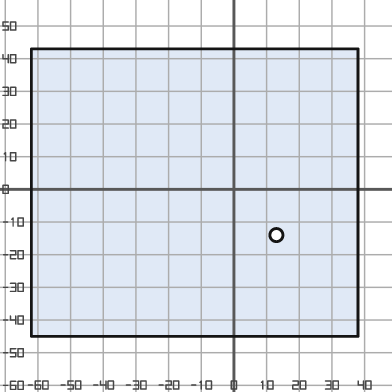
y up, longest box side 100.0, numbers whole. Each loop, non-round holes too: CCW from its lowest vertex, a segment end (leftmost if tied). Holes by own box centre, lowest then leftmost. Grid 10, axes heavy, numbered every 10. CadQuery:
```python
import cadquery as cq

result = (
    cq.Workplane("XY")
    .moveTo(-62.0, -45.0)
    .lineTo(38.0, -45.0)
    .lineTo(38.0, 43.0)
    .lineTo(-62.0, 43.0)
    .close()
    .moveTo(13.0, -14.0)
    .circle(2.0)
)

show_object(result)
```